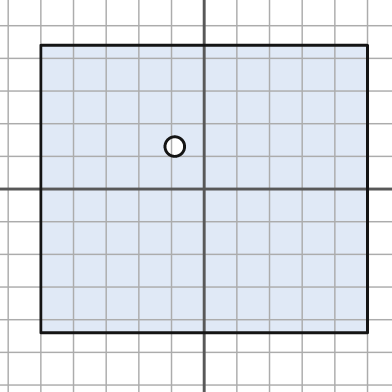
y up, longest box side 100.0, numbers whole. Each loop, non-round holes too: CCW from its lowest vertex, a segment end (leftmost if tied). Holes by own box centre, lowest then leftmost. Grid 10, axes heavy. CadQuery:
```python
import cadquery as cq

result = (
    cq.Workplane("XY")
    .moveTo(-50.0, -44.0)
    .lineTo(50.0, -44.0)
    .lineTo(50.0, 44.0)
    .lineTo(-50.0, 44.0)
    .close()
    .moveTo(-9.0, 13.0)
    .circle(3.0)
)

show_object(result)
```